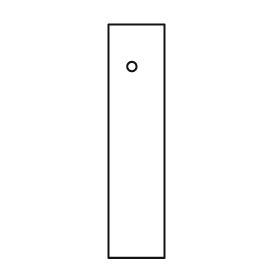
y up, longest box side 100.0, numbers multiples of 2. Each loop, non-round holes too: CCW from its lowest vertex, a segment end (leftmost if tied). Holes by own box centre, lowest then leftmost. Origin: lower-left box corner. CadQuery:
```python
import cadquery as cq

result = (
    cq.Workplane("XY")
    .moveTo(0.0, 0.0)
    .lineTo(24.0, 0.0)
    .lineTo(24.0, 100.0)
    .lineTo(0.0, 100.0)
    .close()
    .moveTo(10.0, 82.0)
    .circle(2.0)
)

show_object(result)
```